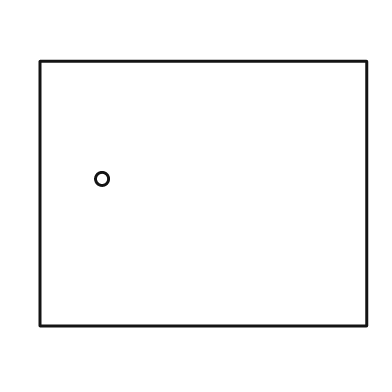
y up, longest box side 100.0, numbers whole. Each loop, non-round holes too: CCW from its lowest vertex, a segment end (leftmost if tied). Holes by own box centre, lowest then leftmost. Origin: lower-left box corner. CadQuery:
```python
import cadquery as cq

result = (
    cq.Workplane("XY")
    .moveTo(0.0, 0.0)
    .lineTo(100.0, 0.0)
    .lineTo(100.0, 81.0)
    .lineTo(0.0, 81.0)
    .close()
    .moveTo(19.0, 45.0)
    .circle(2.0)
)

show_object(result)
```